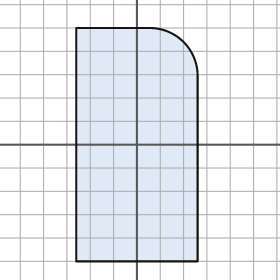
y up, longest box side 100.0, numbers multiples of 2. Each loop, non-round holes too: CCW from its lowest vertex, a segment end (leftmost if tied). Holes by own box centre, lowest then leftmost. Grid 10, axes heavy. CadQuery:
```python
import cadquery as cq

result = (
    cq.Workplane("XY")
    .moveTo(-26.0, -50.0)
    .lineTo(26.0, -50.0)
    .lineTo(26.0, 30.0)
    .threePointArc((20.0, 44.0), (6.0, 50.0))
    .lineTo(-26.0, 50.0)
    .close()
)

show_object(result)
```